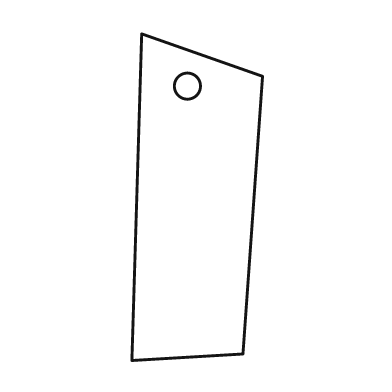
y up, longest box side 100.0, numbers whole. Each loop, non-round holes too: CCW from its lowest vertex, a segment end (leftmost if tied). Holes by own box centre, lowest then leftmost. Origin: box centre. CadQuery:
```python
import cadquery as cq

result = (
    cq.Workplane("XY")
    .moveTo(-20.0, -50.0)
    .lineTo(14.0, -48.0)
    .lineTo(20.0, 37.0)
    .lineTo(-17.0, 50.0)
    .close()
    .moveTo(-3.0, 34.0)
    .circle(4.0)
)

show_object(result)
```